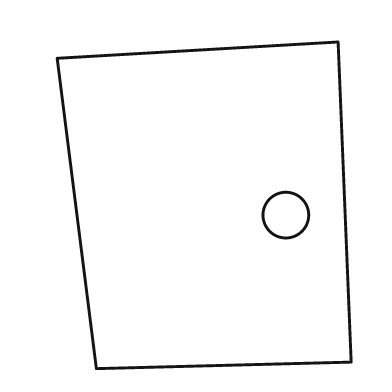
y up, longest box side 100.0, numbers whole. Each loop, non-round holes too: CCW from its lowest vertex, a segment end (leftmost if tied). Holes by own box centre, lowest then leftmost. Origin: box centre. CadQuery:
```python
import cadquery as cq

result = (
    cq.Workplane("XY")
    .moveTo(-33.0, -50.0)
    .lineTo(45.0, -48.0)
    .lineTo(41.0, 50.0)
    .lineTo(-45.0, 45.0)
    .close()
    .moveTo(25.0, -3.0)
    .circle(7.0)
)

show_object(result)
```